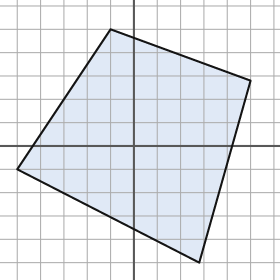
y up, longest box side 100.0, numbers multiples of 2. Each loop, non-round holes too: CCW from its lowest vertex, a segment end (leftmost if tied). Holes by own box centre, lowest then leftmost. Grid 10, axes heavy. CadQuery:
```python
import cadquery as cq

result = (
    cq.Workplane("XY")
    .moveTo(28.0, -50.0)
    .lineTo(50.0, 28.0)
    .lineTo(-10.0, 50.0)
    .lineTo(-50.0, -10.0)
    .close()
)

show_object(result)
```